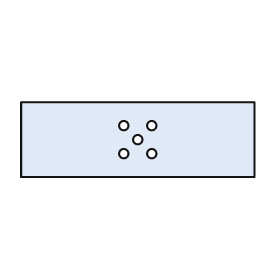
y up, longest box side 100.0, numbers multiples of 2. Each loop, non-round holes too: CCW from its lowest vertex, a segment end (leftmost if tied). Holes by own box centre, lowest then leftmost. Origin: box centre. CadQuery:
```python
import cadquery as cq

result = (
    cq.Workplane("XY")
    .moveTo(-50.0, -16.0)
    .lineTo(50.0, -16.0)
    .lineTo(50.0, 16.0)
    .lineTo(-50.0, 16.0)
    .close()
    .moveTo(-6.0, -6.0)
    .circle(2.0)
    .moveTo(6.0, -6.0)
    .circle(2.0)
    .moveTo(0.0, 0.0)
    .circle(2.0)
    .moveTo(-6.0, 6.0)
    .circle(2.0)
    .moveTo(6.0, 6.0)
    .circle(2.0)
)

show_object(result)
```